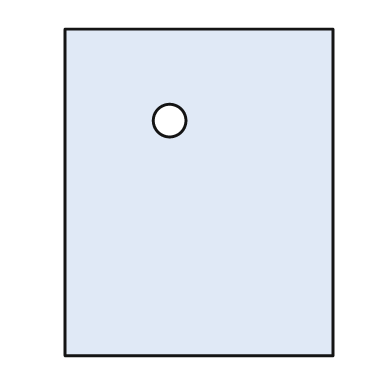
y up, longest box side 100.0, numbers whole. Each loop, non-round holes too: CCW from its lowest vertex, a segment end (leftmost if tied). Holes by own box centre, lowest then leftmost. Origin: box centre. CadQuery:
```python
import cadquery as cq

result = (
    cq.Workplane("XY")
    .moveTo(-41.0, -50.0)
    .lineTo(41.0, -50.0)
    .lineTo(41.0, 50.0)
    .lineTo(-41.0, 50.0)
    .close()
    .moveTo(-9.0, 22.0)
    .circle(5.0)
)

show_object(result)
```